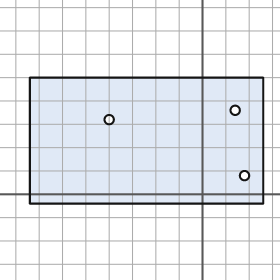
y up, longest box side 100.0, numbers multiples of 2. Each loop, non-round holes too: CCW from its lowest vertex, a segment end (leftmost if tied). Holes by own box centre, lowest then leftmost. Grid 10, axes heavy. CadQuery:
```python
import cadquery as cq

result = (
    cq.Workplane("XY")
    .moveTo(-74.0, -4.0)
    .lineTo(26.0, -4.0)
    .lineTo(26.0, 50.0)
    .lineTo(-74.0, 50.0)
    .close()
    .moveTo(18.0, 8.0)
    .circle(2.0)
    .moveTo(-40.0, 32.0)
    .circle(2.0)
    .moveTo(14.0, 36.0)
    .circle(2.0)
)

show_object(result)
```